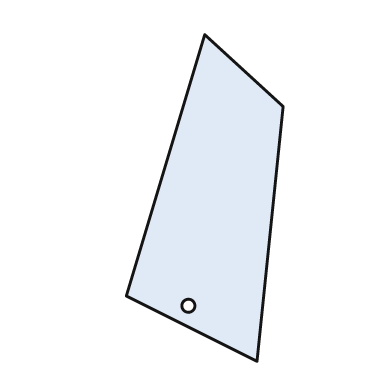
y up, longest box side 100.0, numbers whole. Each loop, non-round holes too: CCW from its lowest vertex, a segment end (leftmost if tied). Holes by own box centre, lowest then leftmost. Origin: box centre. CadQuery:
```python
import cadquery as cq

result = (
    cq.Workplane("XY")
    .moveTo(16.0, -50.0)
    .lineTo(24.0, 28.0)
    .lineTo(0.0, 50.0)
    .lineTo(-24.0, -30.0)
    .close()
    .moveTo(-5.0, -33.0)
    .circle(2.0)
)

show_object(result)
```